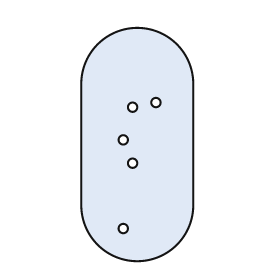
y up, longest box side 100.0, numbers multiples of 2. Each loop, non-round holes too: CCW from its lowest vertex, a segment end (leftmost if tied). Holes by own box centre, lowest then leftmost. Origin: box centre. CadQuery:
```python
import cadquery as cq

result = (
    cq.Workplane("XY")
    .moveTo(-24.0, -26.0)
    .threePointArc((0.0, -50.0), (24.0, -26.0))
    .lineTo(24.0, 26.0)
    .threePointArc((0.0, 50.0), (-24.0, 26.0))
    .close()
    .moveTo(-6.0, -36.0)
    .circle(2.0)
    .moveTo(-2.0, -8.0)
    .circle(2.0)
    .moveTo(-6.0, 2.0)
    .circle(2.0)
    .moveTo(-2.0, 16.0)
    .circle(2.0)
    .moveTo(8.0, 18.0)
    .circle(2.0)
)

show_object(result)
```